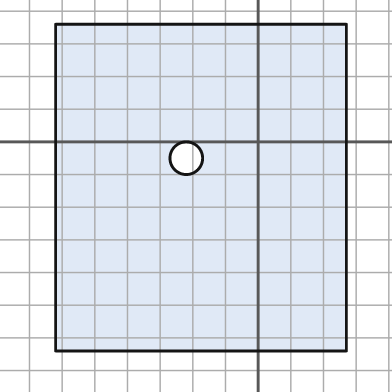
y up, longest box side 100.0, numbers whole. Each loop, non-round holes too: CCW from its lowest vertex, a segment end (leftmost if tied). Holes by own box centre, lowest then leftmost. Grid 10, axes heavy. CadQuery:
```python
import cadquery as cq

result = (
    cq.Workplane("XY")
    .moveTo(-62.0, -64.0)
    .lineTo(27.0, -64.0)
    .lineTo(27.0, 36.0)
    .lineTo(-62.0, 36.0)
    .close()
    .moveTo(-22.0, -5.0)
    .circle(5.0)
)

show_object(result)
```